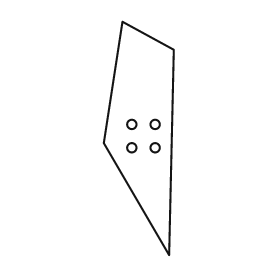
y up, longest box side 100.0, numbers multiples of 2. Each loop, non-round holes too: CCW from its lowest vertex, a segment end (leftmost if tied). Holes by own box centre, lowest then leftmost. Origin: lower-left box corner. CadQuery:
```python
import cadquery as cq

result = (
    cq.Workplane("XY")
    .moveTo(28.0, 0.0)
    .lineTo(30.0, 88.0)
    .lineTo(8.0, 100.0)
    .lineTo(0.0, 48.0)
    .close()
    .moveTo(12.0, 46.0)
    .circle(2.0)
    .moveTo(22.0, 46.0)
    .circle(2.0)
    .moveTo(12.0, 56.0)
    .circle(2.0)
    .moveTo(22.0, 56.0)
    .circle(2.0)
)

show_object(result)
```